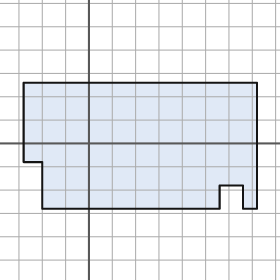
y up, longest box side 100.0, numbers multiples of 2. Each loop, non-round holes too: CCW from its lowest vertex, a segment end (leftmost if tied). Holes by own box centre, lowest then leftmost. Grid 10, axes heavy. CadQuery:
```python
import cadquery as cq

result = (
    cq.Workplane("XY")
    .moveTo(-20.0, -28.0)
    .lineTo(56.0, -28.0)
    .lineTo(56.0, -18.0)
    .lineTo(66.0, -18.0)
    .lineTo(66.0, -28.0)
    .lineTo(72.0, -28.0)
    .lineTo(72.0, 26.0)
    .lineTo(-28.0, 26.0)
    .lineTo(-28.0, -8.0)
    .lineTo(-20.0, -8.0)
    .close()
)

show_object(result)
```